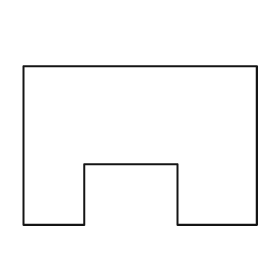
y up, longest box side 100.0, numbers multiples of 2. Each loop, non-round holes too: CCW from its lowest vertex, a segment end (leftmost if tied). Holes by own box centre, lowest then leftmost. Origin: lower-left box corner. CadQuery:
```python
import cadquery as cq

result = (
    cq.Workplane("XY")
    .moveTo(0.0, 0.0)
    .lineTo(26.0, 0.0)
    .lineTo(26.0, 26.0)
    .lineTo(66.0, 26.0)
    .lineTo(66.0, 0.0)
    .lineTo(100.0, 0.0)
    .lineTo(100.0, 68.0)
    .lineTo(0.0, 68.0)
    .close()
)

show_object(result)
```